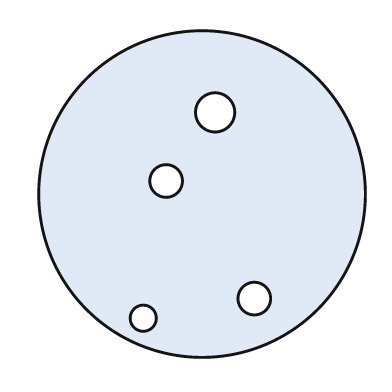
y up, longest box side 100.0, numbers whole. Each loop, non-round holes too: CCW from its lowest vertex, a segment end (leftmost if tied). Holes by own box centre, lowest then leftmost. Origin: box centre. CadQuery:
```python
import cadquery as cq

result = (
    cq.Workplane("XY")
    .moveTo(0.0, 0.0)
    .circle(50.0)
    .moveTo(-18.0, -38.0)
    .circle(4.0)
    .moveTo(16.0, -32.0)
    .circle(5.0)
    .moveTo(-11.0, 4.0)
    .circle(5.0)
    .moveTo(4.0, 25.0)
    .circle(6.0)
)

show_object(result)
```